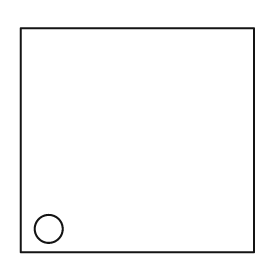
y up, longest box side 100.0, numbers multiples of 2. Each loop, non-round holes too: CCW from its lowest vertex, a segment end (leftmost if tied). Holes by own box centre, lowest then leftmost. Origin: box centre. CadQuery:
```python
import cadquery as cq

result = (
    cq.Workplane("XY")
    .moveTo(-50.0, -48.0)
    .lineTo(50.0, -48.0)
    .lineTo(50.0, 48.0)
    .lineTo(-50.0, 48.0)
    .close()
    .moveTo(-38.0, -38.0)
    .circle(6.0)
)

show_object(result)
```